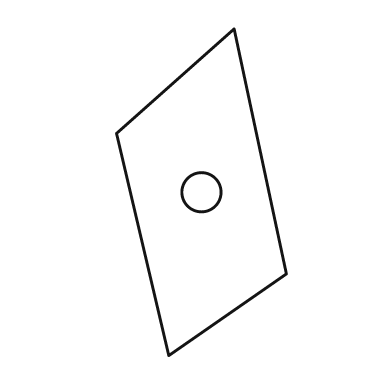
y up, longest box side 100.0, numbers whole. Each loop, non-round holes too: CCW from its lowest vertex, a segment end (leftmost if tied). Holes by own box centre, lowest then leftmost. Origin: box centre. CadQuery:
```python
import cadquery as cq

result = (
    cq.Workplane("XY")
    .moveTo(-10.0, -50.0)
    .lineTo(26.0, -25.0)
    .lineTo(10.0, 50.0)
    .lineTo(-26.0, 18.0)
    .close()
    .moveTo(0.0, 0.0)
    .circle(6.0)
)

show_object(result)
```